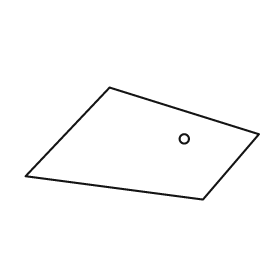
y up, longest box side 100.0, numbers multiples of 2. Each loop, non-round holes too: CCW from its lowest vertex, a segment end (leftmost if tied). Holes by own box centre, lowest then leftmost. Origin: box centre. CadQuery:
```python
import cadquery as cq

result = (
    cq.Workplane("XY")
    .moveTo(26.0, -24.0)
    .lineTo(50.0, 4.0)
    .lineTo(-14.0, 24.0)
    .lineTo(-50.0, -14.0)
    .close()
    .moveTo(18.0, 2.0)
    .circle(2.0)
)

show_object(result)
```